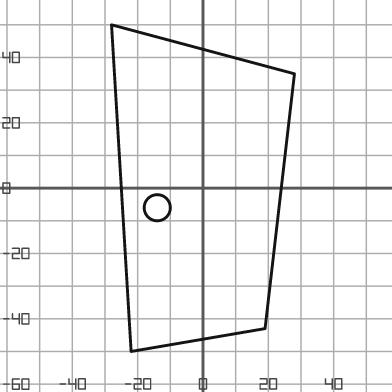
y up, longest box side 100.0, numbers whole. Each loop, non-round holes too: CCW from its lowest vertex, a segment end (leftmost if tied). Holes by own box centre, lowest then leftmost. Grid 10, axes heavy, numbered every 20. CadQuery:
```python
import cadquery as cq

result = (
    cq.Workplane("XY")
    .moveTo(-22.0, -50.0)
    .lineTo(19.0, -43.0)
    .lineTo(28.0, 35.0)
    .lineTo(-28.0, 50.0)
    .close()
    .moveTo(-14.0, -6.0)
    .circle(4.0)
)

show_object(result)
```